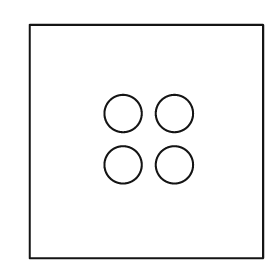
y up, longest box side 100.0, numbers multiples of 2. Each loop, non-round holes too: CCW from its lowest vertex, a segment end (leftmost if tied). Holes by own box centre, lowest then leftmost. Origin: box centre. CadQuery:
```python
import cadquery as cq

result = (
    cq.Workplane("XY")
    .moveTo(-50.0, -50.0)
    .lineTo(50.0, -50.0)
    .lineTo(50.0, 50.0)
    .lineTo(-50.0, 50.0)
    .close()
    .moveTo(-10.0, -10.0)
    .circle(8.0)
    .moveTo(12.0, -10.0)
    .circle(8.0)
    .moveTo(-10.0, 12.0)
    .circle(8.0)
    .moveTo(12.0, 12.0)
    .circle(8.0)
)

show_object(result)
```